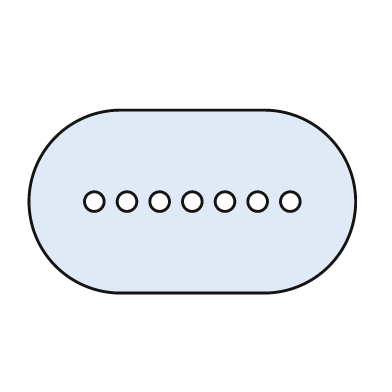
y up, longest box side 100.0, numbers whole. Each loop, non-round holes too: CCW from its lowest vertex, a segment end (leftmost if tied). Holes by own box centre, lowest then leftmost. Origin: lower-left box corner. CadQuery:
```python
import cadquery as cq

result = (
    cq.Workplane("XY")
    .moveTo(28.0, 0.0)
    .lineTo(72.0, 0.0)
    .threePointArc((100.0, 28.0), (72.0, 56.0))
    .lineTo(28.0, 56.0)
    .threePointArc((0.0, 28.0), (28.0, 0.0))
    .close()
    .moveTo(20.0, 28.0)
    .circle(3.0)
    .moveTo(30.0, 28.0)
    .circle(3.0)
    .moveTo(40.0, 28.0)
    .circle(3.0)
    .moveTo(50.0, 28.0)
    .circle(3.0)
    .moveTo(60.0, 28.0)
    .circle(3.0)
    .moveTo(70.0, 28.0)
    .circle(3.0)
    .moveTo(80.0, 28.0)
    .circle(3.0)
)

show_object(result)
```